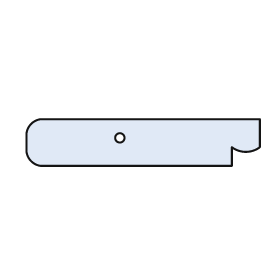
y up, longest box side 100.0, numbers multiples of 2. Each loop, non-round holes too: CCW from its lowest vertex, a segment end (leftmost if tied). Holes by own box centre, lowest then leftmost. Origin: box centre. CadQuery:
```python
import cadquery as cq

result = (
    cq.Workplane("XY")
    .moveTo(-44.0, -10.0)
    .lineTo(38.0, -10.0)
    .lineTo(38.0, -2.0)
    .threePointArc((44.0, -4.0), (50.0, -2.0))
    .lineTo(50.0, 10.0)
    .lineTo(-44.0, 10.0)
    .threePointArc((-48.0, 8.0), (-50.0, 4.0))
    .lineTo(-50.0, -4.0)
    .threePointArc((-48.0, -8.0), (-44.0, -10.0))
    .close()
    .moveTo(-10.0, 2.0)
    .circle(2.0)
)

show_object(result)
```